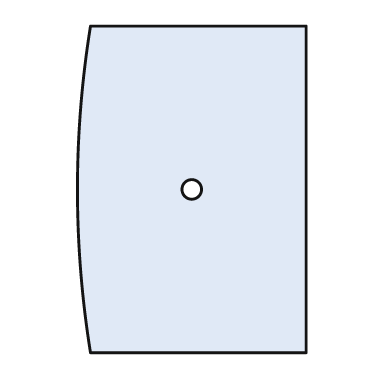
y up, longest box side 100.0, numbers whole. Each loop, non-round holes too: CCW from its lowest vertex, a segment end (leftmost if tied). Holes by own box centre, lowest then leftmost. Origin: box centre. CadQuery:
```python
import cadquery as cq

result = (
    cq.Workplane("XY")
    .moveTo(-31.0, -50.0)
    .lineTo(35.0, -50.0)
    .lineTo(35.0, 50.0)
    .lineTo(-31.0, 50.0)
    .threePointArc((-35.0, 0.0), (-31.0, -50.0))
    .close()
    .moveTo(0.0, 0.0)
    .circle(3.0)
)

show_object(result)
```